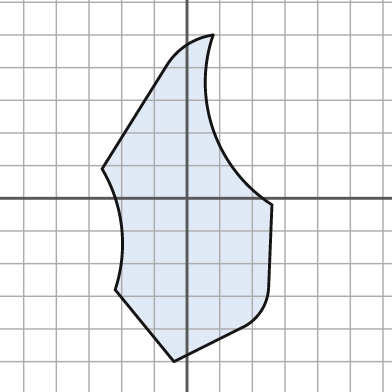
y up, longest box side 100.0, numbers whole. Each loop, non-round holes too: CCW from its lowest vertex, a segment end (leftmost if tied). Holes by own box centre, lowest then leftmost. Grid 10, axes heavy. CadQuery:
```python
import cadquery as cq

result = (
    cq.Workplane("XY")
    .moveTo(-4.0, -50.0)
    .lineTo(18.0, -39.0)
    .threePointArc((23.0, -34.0), (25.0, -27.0))
    .lineTo(26.0, -2.0)
    .threePointArc((8.0, 21.0), (8.0, 50.0))
    .threePointArc((0.0, 47.0), (-6.0, 41.0))
    .lineTo(-26.0, 9.0)
    .threePointArc((-20.0, -9.0), (-22.0, -28.0))
    .close()
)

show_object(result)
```